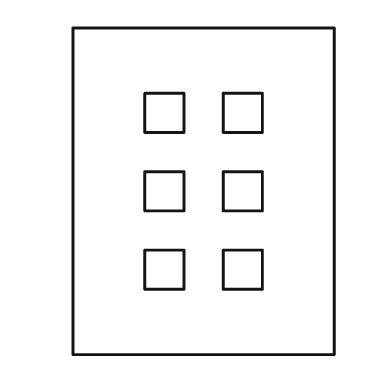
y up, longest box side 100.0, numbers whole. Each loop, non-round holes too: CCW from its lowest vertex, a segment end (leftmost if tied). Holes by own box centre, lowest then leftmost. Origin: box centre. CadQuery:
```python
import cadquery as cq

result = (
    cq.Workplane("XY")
    .moveTo(-40.0, -50.0)
    .lineTo(40.0, -50.0)
    .lineTo(40.0, 50.0)
    .lineTo(-40.0, 50.0)
    .close()
    .moveTo(-18.0, -30.0)
    .lineTo(-6.0, -30.0)
    .lineTo(-6.0, -18.0)
    .lineTo(-18.0, -18.0)
    .close()
    .moveTo(6.0, -30.0)
    .lineTo(18.0, -30.0)
    .lineTo(18.0, -18.0)
    .lineTo(6.0, -18.0)
    .close()
    .moveTo(-18.0, -6.0)
    .lineTo(-6.0, -6.0)
    .lineTo(-6.0, 6.0)
    .lineTo(-18.0, 6.0)
    .close()
    .moveTo(6.0, -6.0)
    .lineTo(18.0, -6.0)
    .lineTo(18.0, 6.0)
    .lineTo(6.0, 6.0)
    .close()
    .moveTo(-18.0, 18.0)
    .lineTo(-6.0, 18.0)
    .lineTo(-6.0, 30.0)
    .lineTo(-18.0, 30.0)
    .close()
    .moveTo(6.0, 18.0)
    .lineTo(18.0, 18.0)
    .lineTo(18.0, 30.0)
    .lineTo(6.0, 30.0)
    .close()
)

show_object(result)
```